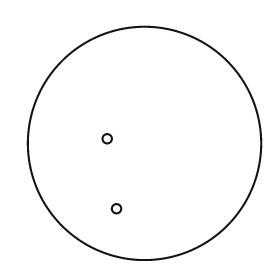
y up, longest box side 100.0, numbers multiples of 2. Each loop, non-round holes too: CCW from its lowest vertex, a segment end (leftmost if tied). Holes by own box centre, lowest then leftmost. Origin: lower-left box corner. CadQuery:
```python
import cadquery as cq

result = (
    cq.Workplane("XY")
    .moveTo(50.0, 50.0)
    .circle(50.0)
    .moveTo(38.0, 22.0)
    .circle(2.0)
    .moveTo(34.0, 52.0)
    .circle(2.0)
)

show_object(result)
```